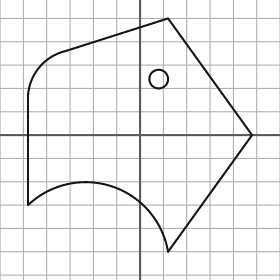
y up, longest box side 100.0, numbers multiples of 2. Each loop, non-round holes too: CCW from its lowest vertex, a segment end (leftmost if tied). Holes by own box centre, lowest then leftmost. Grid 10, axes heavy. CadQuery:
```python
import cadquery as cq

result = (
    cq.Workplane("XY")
    .moveTo(12.0, -50.0)
    .lineTo(48.0, 0.0)
    .lineTo(12.0, 50.0)
    .lineTo(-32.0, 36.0)
    .threePointArc((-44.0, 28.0), (-48.0, 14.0))
    .lineTo(-48.0, -30.0)
    .threePointArc((-12.0, -22.0), (12.0, -50.0))
    .close()
    .moveTo(8.0, 24.0)
    .circle(4.0)
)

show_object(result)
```